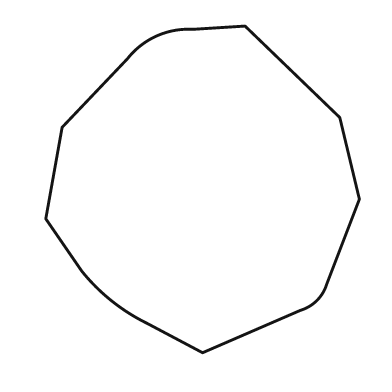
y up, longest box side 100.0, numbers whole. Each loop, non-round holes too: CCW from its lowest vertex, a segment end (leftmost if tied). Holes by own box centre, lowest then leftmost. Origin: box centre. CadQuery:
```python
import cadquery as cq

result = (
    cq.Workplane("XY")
    .moveTo(0.0, -50.0)
    .lineTo(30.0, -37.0)
    .threePointArc((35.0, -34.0), (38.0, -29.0))
    .lineTo(48.0, -3.0)
    .lineTo(42.0, 22.0)
    .lineTo(13.0, 50.0)
    .lineTo(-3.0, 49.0)
    .threePointArc((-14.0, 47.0), (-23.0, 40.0))
    .lineTo(-43.0, 19.0)
    .lineTo(-48.0, -9.0)
    .lineTo(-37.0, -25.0)
    .threePointArc((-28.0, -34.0), (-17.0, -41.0))
    .close()
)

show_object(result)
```